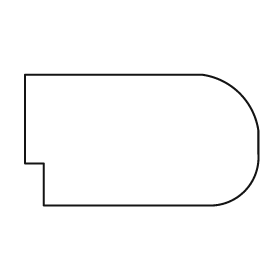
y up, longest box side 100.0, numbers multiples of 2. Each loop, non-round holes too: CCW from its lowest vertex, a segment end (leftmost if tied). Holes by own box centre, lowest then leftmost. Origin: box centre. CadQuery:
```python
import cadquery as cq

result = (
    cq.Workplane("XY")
    .moveTo(-42.0, -28.0)
    .lineTo(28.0, -28.0)
    .threePointArc((44.0, -22.0), (50.0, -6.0))
    .lineTo(50.0, 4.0)
    .threePointArc((42.0, 20.0), (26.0, 28.0))
    .lineTo(-50.0, 28.0)
    .lineTo(-50.0, -10.0)
    .lineTo(-42.0, -10.0)
    .close()
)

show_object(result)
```